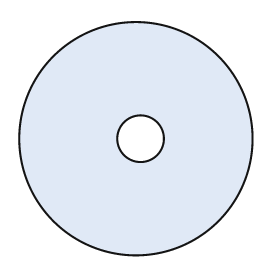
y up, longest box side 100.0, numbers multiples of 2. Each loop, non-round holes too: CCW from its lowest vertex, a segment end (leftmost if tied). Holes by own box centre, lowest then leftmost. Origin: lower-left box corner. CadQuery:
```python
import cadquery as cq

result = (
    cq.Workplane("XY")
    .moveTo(50.0, 50.0)
    .circle(50.0)
    .moveTo(52.0, 50.0)
    .circle(10.0)
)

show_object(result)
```